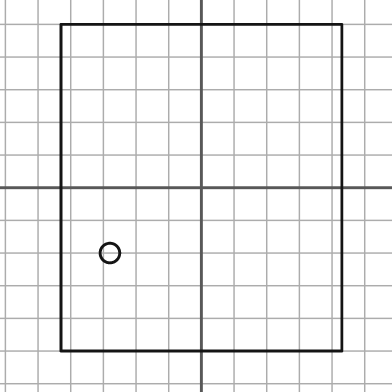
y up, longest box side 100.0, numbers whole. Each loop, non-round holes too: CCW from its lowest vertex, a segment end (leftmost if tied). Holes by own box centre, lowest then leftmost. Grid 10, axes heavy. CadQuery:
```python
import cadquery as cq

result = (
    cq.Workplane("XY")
    .moveTo(-43.0, -50.0)
    .lineTo(43.0, -50.0)
    .lineTo(43.0, 50.0)
    .lineTo(-43.0, 50.0)
    .close()
    .moveTo(-28.0, -20.0)
    .circle(3.0)
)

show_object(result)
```